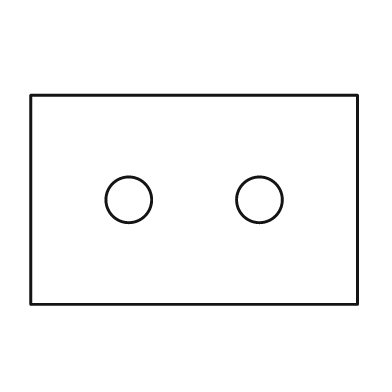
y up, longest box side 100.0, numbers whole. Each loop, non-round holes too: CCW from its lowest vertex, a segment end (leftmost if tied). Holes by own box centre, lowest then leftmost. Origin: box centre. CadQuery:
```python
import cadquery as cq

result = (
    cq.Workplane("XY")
    .moveTo(-50.0, -32.0)
    .lineTo(50.0, -32.0)
    .lineTo(50.0, 32.0)
    .lineTo(-50.0, 32.0)
    .close()
    .moveTo(-20.0, 0.0)
    .circle(7.0)
    .moveTo(20.0, 0.0)
    .circle(7.0)
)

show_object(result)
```